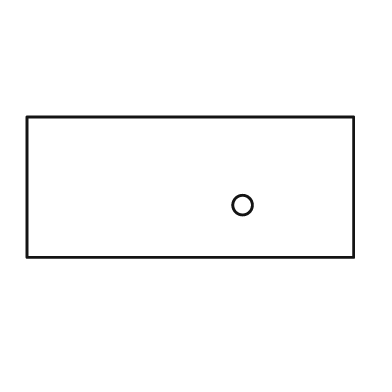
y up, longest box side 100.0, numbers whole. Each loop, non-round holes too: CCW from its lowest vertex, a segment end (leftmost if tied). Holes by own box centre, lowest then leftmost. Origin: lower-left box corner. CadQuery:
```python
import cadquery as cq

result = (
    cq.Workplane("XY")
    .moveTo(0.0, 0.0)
    .lineTo(100.0, 0.0)
    .lineTo(100.0, 43.0)
    .lineTo(0.0, 43.0)
    .close()
    .moveTo(66.0, 16.0)
    .circle(3.0)
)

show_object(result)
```